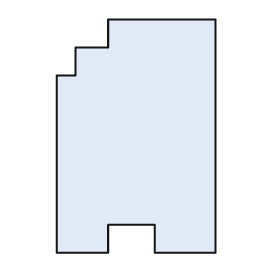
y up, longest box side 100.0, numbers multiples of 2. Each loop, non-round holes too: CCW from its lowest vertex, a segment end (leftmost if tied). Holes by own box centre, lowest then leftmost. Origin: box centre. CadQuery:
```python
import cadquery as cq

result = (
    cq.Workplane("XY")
    .moveTo(-34.0, -50.0)
    .lineTo(-12.0, -50.0)
    .lineTo(-12.0, -38.0)
    .lineTo(8.0, -38.0)
    .lineTo(8.0, -50.0)
    .lineTo(34.0, -50.0)
    .lineTo(34.0, 50.0)
    .lineTo(-12.0, 50.0)
    .lineTo(-12.0, 38.0)
    .lineTo(-26.0, 38.0)
    .lineTo(-26.0, 26.0)
    .lineTo(-34.0, 26.0)
    .close()
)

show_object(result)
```